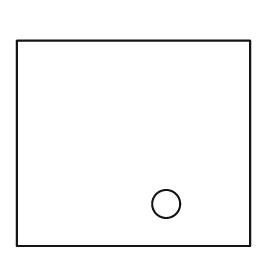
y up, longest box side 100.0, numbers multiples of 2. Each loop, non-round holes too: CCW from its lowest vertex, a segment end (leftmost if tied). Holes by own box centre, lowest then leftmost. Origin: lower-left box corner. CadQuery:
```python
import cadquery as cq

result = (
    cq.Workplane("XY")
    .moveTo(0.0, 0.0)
    .lineTo(100.0, 0.0)
    .lineTo(100.0, 88.0)
    .lineTo(0.0, 88.0)
    .close()
    .moveTo(64.0, 18.0)
    .circle(6.0)
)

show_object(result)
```